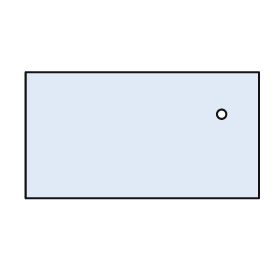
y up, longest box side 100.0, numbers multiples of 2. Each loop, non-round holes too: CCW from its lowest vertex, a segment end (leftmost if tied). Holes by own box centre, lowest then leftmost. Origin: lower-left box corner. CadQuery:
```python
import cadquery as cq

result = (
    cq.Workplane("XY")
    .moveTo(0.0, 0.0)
    .lineTo(100.0, 0.0)
    .lineTo(100.0, 54.0)
    .lineTo(0.0, 54.0)
    .close()
    .moveTo(84.0, 36.0)
    .circle(2.0)
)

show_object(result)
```